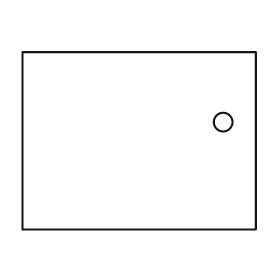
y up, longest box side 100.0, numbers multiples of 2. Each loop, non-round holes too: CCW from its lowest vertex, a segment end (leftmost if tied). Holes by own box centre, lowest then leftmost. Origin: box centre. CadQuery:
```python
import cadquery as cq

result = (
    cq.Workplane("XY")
    .moveTo(-50.0, -38.0)
    .lineTo(50.0, -38.0)
    .lineTo(50.0, 38.0)
    .lineTo(-50.0, 38.0)
    .close()
    .moveTo(36.0, 8.0)
    .circle(4.0)
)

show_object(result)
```